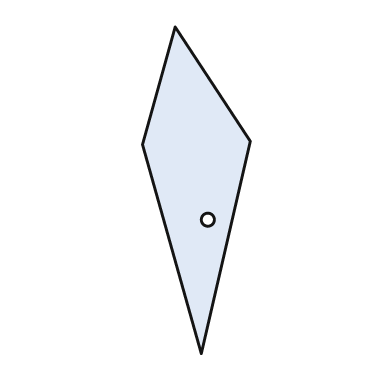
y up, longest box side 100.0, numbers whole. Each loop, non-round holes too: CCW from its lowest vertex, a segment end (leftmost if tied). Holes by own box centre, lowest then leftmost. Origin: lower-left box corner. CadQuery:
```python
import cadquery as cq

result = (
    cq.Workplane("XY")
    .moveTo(18.0, 0.0)
    .lineTo(33.0, 65.0)
    .lineTo(10.0, 100.0)
    .lineTo(0.0, 64.0)
    .close()
    .moveTo(20.0, 41.0)
    .circle(2.0)
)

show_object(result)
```